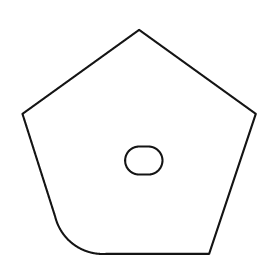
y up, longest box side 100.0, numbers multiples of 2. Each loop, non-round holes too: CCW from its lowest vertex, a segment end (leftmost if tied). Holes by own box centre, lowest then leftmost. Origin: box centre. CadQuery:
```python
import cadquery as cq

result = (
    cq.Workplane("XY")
    .moveTo(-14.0, -48.0)
    .lineTo(30.0, -48.0)
    .lineTo(50.0, 12.0)
    .lineTo(0.0, 48.0)
    .lineTo(-50.0, 12.0)
    .lineTo(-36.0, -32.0)
    .threePointArc((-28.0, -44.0), (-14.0, -48.0))
    .close()
    .moveTo(0.0, -14.0)
    .lineTo(4.0, -14.0)
    .threePointArc((10.0, -8.0), (4.0, -2.0))
    .lineTo(0.0, -2.0)
    .threePointArc((-6.0, -8.0), (0.0, -14.0))
    .close()
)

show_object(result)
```